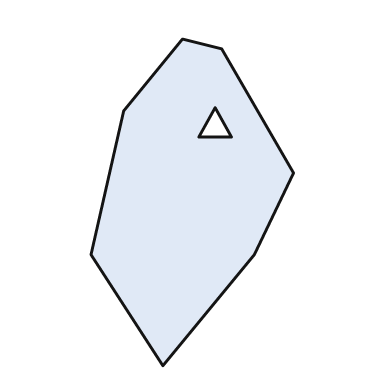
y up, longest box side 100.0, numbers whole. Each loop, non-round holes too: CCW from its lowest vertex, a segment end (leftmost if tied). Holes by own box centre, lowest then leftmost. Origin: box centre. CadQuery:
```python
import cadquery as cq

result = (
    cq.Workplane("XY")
    .moveTo(-9.0, -50.0)
    .lineTo(19.0, -16.0)
    .lineTo(31.0, 9.0)
    .lineTo(9.0, 47.0)
    .lineTo(-3.0, 50.0)
    .lineTo(-21.0, 28.0)
    .lineTo(-31.0, -16.0)
    .close()
    .moveTo(2.0, 20.0)
    .lineTo(12.0, 20.0)
    .lineTo(7.0, 29.0)
    .close()
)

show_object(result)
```